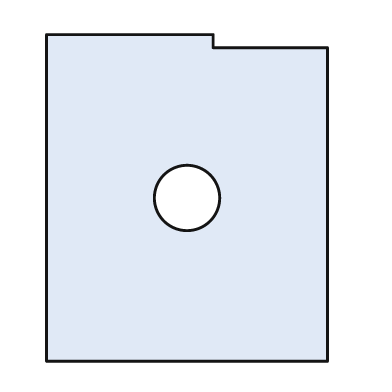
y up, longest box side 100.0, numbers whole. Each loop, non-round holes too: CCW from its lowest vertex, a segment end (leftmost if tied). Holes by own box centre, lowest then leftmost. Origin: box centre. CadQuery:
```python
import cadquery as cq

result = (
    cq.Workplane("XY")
    .moveTo(-43.0, -50.0)
    .lineTo(43.0, -50.0)
    .lineTo(43.0, 46.0)
    .lineTo(8.0, 46.0)
    .lineTo(8.0, 50.0)
    .lineTo(-43.0, 50.0)
    .close()
    .moveTo(0.0, 0.0)
    .circle(10.0)
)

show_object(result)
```